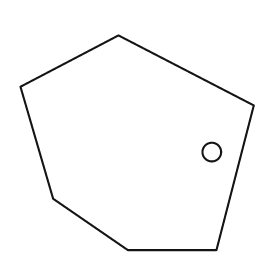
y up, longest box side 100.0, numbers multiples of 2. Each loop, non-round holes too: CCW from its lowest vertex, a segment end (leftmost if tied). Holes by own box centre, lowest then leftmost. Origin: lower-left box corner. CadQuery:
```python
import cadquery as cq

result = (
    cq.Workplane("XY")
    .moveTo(46.0, 0.0)
    .lineTo(84.0, 0.0)
    .lineTo(100.0, 62.0)
    .lineTo(42.0, 92.0)
    .lineTo(0.0, 70.0)
    .lineTo(14.0, 22.0)
    .close()
    .moveTo(82.0, 42.0)
    .circle(4.0)
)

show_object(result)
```